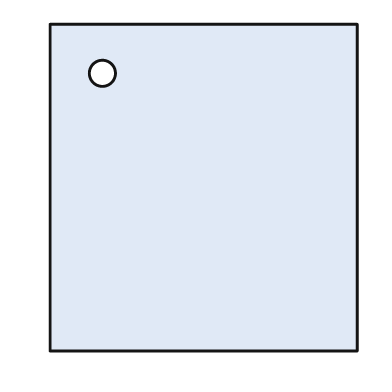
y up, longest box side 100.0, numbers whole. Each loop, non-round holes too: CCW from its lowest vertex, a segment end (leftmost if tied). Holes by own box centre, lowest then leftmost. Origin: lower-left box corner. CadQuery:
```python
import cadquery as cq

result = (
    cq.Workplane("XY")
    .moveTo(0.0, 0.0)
    .lineTo(94.0, 0.0)
    .lineTo(94.0, 100.0)
    .lineTo(0.0, 100.0)
    .close()
    .moveTo(16.0, 85.0)
    .circle(4.0)
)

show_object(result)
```